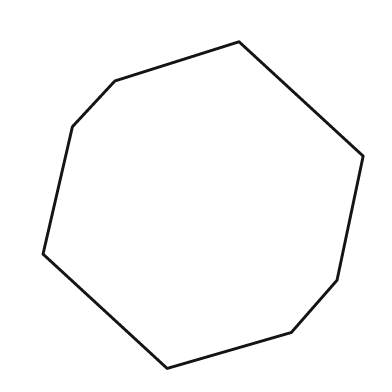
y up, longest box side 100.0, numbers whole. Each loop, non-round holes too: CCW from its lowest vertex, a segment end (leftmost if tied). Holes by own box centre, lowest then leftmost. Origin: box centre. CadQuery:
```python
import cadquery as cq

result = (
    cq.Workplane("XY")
    .moveTo(-11.0, -50.0)
    .lineTo(27.0, -39.0)
    .lineTo(41.0, -23.0)
    .lineTo(49.0, 15.0)
    .lineTo(11.0, 50.0)
    .lineTo(-27.0, 38.0)
    .lineTo(-40.0, 24.0)
    .lineTo(-49.0, -15.0)
    .close()
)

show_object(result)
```